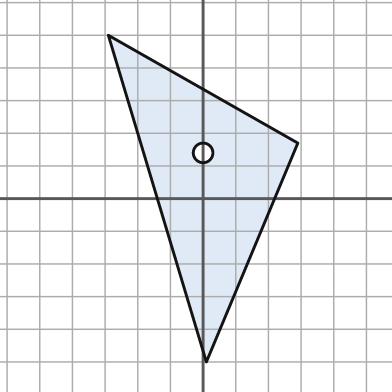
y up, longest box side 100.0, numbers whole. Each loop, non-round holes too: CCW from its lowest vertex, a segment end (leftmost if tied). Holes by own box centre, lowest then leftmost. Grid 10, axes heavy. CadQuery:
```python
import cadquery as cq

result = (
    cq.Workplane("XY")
    .moveTo(1.0, -50.0)
    .lineTo(29.0, 17.0)
    .lineTo(-29.0, 50.0)
    .close()
    .moveTo(0.0, 14.0)
    .circle(3.0)
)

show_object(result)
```